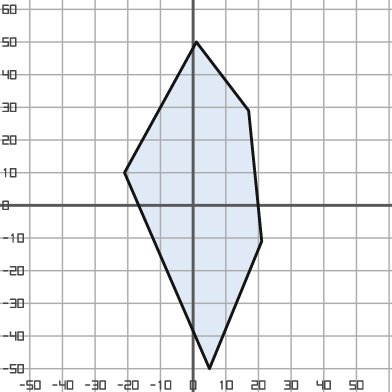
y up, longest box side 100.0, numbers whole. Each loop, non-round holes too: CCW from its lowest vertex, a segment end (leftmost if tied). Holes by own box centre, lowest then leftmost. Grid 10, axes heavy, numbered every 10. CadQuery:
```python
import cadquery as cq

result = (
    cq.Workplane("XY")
    .moveTo(5.0, -50.0)
    .lineTo(21.0, -11.0)
    .lineTo(17.0, 29.0)
    .lineTo(1.0, 50.0)
    .lineTo(-21.0, 10.0)
    .close()
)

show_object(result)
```